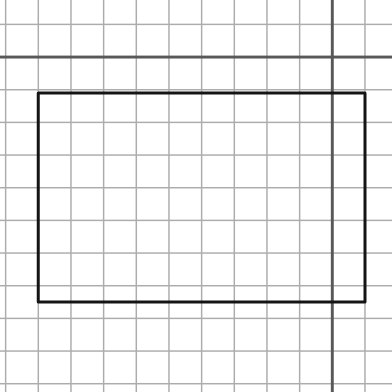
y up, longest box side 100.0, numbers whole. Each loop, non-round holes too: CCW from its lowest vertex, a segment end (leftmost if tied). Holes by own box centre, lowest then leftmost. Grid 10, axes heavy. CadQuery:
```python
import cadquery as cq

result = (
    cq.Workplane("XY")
    .moveTo(-90.0, -75.0)
    .lineTo(10.0, -75.0)
    .lineTo(10.0, -11.0)
    .lineTo(-90.0, -11.0)
    .close()
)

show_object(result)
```